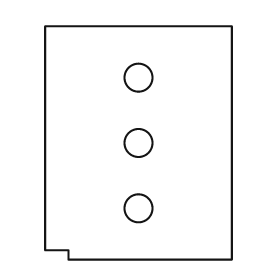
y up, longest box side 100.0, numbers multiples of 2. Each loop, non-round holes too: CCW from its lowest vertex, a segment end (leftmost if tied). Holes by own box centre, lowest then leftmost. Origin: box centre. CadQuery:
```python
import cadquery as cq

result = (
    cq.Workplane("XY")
    .moveTo(-30.0, -50.0)
    .lineTo(40.0, -50.0)
    .lineTo(40.0, 50.0)
    .lineTo(-40.0, 50.0)
    .lineTo(-40.0, -46.0)
    .lineTo(-30.0, -46.0)
    .close()
    .moveTo(0.0, -28.0)
    .circle(6.0)
    .moveTo(0.0, 0.0)
    .circle(6.0)
    .moveTo(0.0, 28.0)
    .circle(6.0)
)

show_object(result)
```